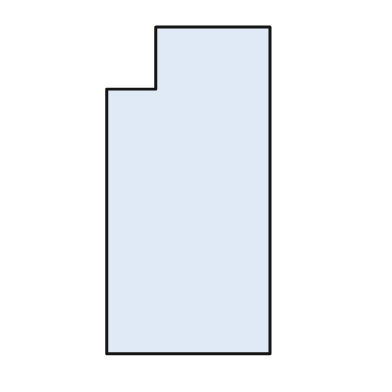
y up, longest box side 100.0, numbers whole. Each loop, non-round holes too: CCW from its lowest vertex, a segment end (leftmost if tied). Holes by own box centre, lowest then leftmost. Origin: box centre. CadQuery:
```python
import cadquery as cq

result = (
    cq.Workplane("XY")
    .moveTo(-25.0, -50.0)
    .lineTo(25.0, -50.0)
    .lineTo(25.0, 50.0)
    .lineTo(-10.0, 50.0)
    .lineTo(-10.0, 31.0)
    .lineTo(-25.0, 31.0)
    .close()
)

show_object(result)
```